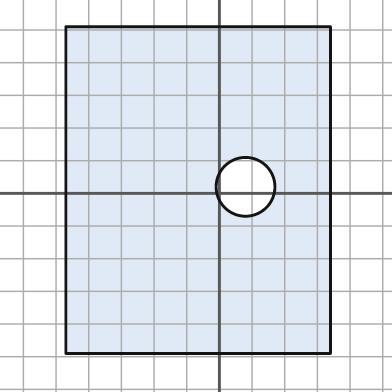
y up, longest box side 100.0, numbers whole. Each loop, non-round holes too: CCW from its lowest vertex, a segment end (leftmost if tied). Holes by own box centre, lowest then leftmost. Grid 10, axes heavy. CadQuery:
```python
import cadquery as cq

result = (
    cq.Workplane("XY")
    .moveTo(-47.0, -49.0)
    .lineTo(34.0, -49.0)
    .lineTo(34.0, 51.0)
    .lineTo(-47.0, 51.0)
    .close()
    .moveTo(8.0, 2.0)
    .circle(9.0)
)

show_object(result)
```